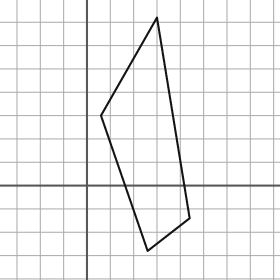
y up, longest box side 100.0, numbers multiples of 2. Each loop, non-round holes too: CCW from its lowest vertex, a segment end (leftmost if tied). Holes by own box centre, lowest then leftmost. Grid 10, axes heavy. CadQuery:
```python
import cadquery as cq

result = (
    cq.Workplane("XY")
    .moveTo(26.0, -28.0)
    .lineTo(44.0, -14.0)
    .lineTo(30.0, 72.0)
    .lineTo(6.0, 30.0)
    .close()
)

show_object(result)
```